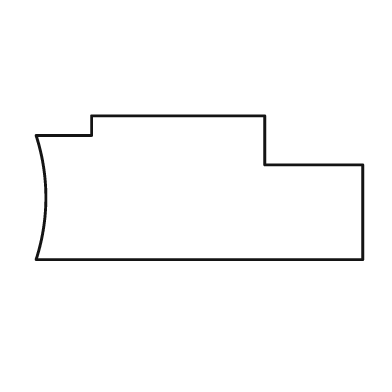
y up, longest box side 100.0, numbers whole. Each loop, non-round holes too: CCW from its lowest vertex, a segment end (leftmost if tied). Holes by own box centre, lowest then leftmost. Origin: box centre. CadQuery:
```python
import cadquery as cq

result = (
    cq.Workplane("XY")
    .moveTo(-50.0, -22.0)
    .lineTo(50.0, -22.0)
    .lineTo(50.0, 7.0)
    .lineTo(20.0, 7.0)
    .lineTo(20.0, 22.0)
    .lineTo(-33.0, 22.0)
    .lineTo(-33.0, 16.0)
    .lineTo(-50.0, 16.0)
    .threePointArc((-47.0, -3.0), (-50.0, -22.0))
    .close()
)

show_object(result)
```